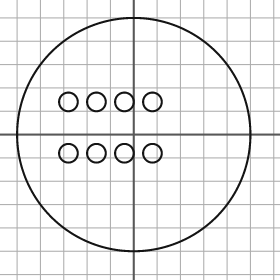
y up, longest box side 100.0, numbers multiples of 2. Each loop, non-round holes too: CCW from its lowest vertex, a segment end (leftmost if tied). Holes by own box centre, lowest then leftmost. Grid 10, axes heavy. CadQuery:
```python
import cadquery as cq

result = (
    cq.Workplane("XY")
    .moveTo(0.0, 0.0)
    .circle(50.0)
    .moveTo(-28.0, -8.0)
    .circle(4.0)
    .moveTo(-16.0, -8.0)
    .circle(4.0)
    .moveTo(-4.0, -8.0)
    .circle(4.0)
    .moveTo(8.0, -8.0)
    .circle(4.0)
    .moveTo(-28.0, 14.0)
    .circle(4.0)
    .moveTo(-16.0, 14.0)
    .circle(4.0)
    .moveTo(-4.0, 14.0)
    .circle(4.0)
    .moveTo(8.0, 14.0)
    .circle(4.0)
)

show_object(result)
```